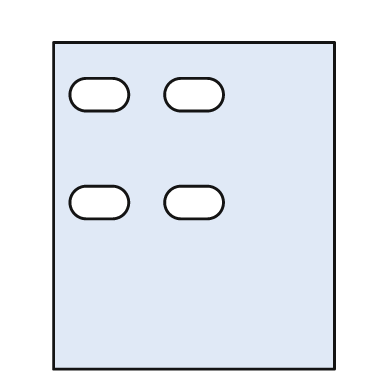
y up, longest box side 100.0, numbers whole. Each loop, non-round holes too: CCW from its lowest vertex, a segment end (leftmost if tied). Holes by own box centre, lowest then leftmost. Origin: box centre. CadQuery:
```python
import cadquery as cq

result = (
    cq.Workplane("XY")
    .moveTo(-43.0, -50.0)
    .lineTo(43.0, -50.0)
    .lineTo(43.0, 50.0)
    .lineTo(-43.0, 50.0)
    .close()
    .moveTo(-33.0, -4.0)
    .lineTo(-25.0, -4.0)
    .threePointArc((-20.0, 1.0), (-25.0, 6.0))
    .lineTo(-33.0, 6.0)
    .threePointArc((-38.0, 1.0), (-33.0, -4.0))
    .close()
    .moveTo(-4.0, -4.0)
    .lineTo(4.0, -4.0)
    .threePointArc((9.0, 1.0), (4.0, 6.0))
    .lineTo(-4.0, 6.0)
    .threePointArc((-9.0, 1.0), (-4.0, -4.0))
    .close()
    .moveTo(-33.0, 29.0)
    .lineTo(-25.0, 29.0)
    .threePointArc((-20.0, 34.0), (-25.0, 39.0))
    .lineTo(-33.0, 39.0)
    .threePointArc((-38.0, 34.0), (-33.0, 29.0))
    .close()
    .moveTo(-4.0, 29.0)
    .lineTo(4.0, 29.0)
    .threePointArc((9.0, 34.0), (4.0, 39.0))
    .lineTo(-4.0, 39.0)
    .threePointArc((-9.0, 34.0), (-4.0, 29.0))
    .close()
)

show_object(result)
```